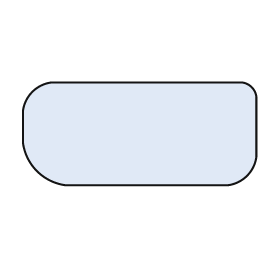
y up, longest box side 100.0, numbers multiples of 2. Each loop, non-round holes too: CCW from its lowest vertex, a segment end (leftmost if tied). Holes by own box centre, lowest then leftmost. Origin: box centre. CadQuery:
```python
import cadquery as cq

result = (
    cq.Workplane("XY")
    .moveTo(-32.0, -22.0)
    .lineTo(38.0, -22.0)
    .threePointArc((46.0, -18.0), (50.0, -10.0))
    .lineTo(50.0, 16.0)
    .threePointArc((48.0, 20.0), (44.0, 22.0))
    .lineTo(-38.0, 22.0)
    .threePointArc((-46.0, 18.0), (-50.0, 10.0))
    .lineTo(-50.0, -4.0)
    .threePointArc((-44.0, -16.0), (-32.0, -22.0))
    .close()
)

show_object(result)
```